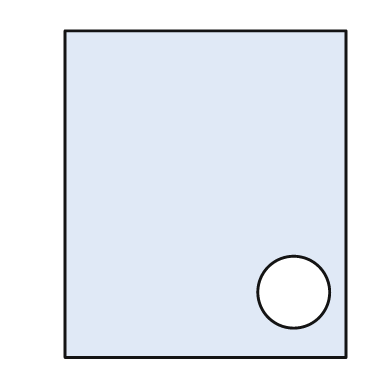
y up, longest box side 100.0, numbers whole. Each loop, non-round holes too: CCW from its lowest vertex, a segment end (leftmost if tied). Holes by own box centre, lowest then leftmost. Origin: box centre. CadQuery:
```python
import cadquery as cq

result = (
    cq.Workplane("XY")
    .moveTo(-43.0, -50.0)
    .lineTo(43.0, -50.0)
    .lineTo(43.0, 50.0)
    .lineTo(-43.0, 50.0)
    .close()
    .moveTo(27.0, -30.0)
    .circle(11.0)
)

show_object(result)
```